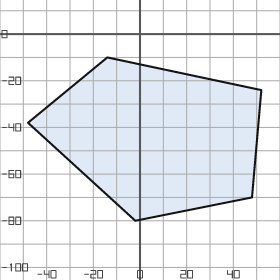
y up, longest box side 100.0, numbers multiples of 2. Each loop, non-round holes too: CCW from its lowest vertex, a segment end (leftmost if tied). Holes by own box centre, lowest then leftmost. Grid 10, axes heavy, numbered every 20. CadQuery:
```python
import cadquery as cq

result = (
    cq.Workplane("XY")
    .moveTo(-2.0, -80.0)
    .lineTo(48.0, -70.0)
    .lineTo(52.0, -24.0)
    .lineTo(-14.0, -10.0)
    .lineTo(-48.0, -38.0)
    .close()
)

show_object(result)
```